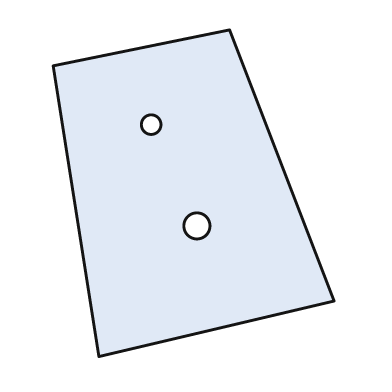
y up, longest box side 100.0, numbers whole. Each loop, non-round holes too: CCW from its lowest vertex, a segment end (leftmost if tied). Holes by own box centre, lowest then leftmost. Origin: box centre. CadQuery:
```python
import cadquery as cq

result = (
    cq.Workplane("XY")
    .moveTo(-29.0, -50.0)
    .lineTo(43.0, -33.0)
    .lineTo(11.0, 50.0)
    .lineTo(-43.0, 39.0)
    .close()
    .moveTo(1.0, -10.0)
    .circle(4.0)
    .moveTo(-13.0, 21.0)
    .circle(3.0)
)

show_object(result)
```